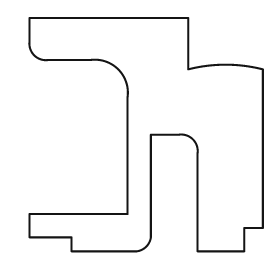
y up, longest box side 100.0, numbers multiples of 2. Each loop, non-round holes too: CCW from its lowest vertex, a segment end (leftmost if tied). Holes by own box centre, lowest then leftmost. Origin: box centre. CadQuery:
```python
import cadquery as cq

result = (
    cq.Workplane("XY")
    .moveTo(-32.0, -50.0)
    .lineTo(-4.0, -50.0)
    .threePointArc((0.0, -48.0), (2.0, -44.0))
    .lineTo(2.0, 0.0)
    .lineTo(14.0, 0.0)
    .threePointArc((20.0, -2.0), (22.0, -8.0))
    .lineTo(22.0, -50.0)
    .lineTo(42.0, -50.0)
    .lineTo(42.0, -40.0)
    .lineTo(50.0, -40.0)
    .lineTo(50.0, 28.0)
    .threePointArc((34.0, 30.0), (18.0, 28.0))
    .lineTo(18.0, 50.0)
    .lineTo(-50.0, 50.0)
    .lineTo(-50.0, 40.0)
    .threePointArc((-48.0, 34.0), (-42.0, 32.0))
    .lineTo(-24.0, 32.0)
    .threePointArc((-12.0, 28.0), (-8.0, 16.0))
    .lineTo(-8.0, -34.0)
    .lineTo(-50.0, -34.0)
    .lineTo(-50.0, -44.0)
    .lineTo(-32.0, -44.0)
    .close()
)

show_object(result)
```